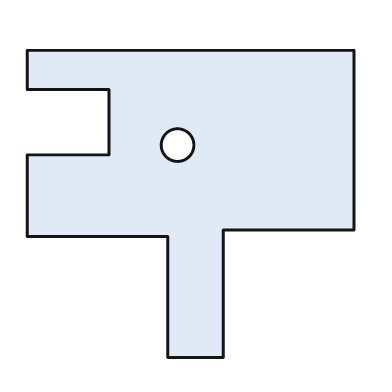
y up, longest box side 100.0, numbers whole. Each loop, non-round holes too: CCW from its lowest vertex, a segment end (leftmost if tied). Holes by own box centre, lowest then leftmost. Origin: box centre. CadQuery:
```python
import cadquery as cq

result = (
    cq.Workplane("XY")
    .moveTo(-7.0, -47.0)
    .lineTo(10.0, -47.0)
    .lineTo(10.0, -8.0)
    .lineTo(50.0, -8.0)
    .lineTo(50.0, 47.0)
    .lineTo(-50.0, 47.0)
    .lineTo(-50.0, 35.0)
    .lineTo(-25.0, 35.0)
    .lineTo(-25.0, 15.0)
    .lineTo(-50.0, 15.0)
    .lineTo(-50.0, -10.0)
    .lineTo(-7.0, -10.0)
    .close()
    .moveTo(-4.0, 18.0)
    .circle(5.0)
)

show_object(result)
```